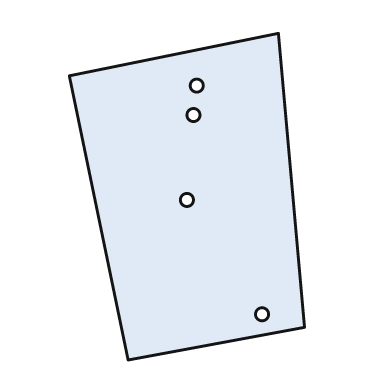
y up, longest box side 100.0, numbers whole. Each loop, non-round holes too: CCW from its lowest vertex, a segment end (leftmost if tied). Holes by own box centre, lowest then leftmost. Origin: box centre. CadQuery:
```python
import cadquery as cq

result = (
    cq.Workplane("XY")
    .moveTo(-18.0, -50.0)
    .lineTo(36.0, -40.0)
    .lineTo(28.0, 50.0)
    .lineTo(-36.0, 37.0)
    .close()
    .moveTo(23.0, -36.0)
    .circle(2.0)
    .moveTo(0.0, -1.0)
    .circle(2.0)
    .moveTo(2.0, 25.0)
    .circle(2.0)
    .moveTo(3.0, 34.0)
    .circle(2.0)
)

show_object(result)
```